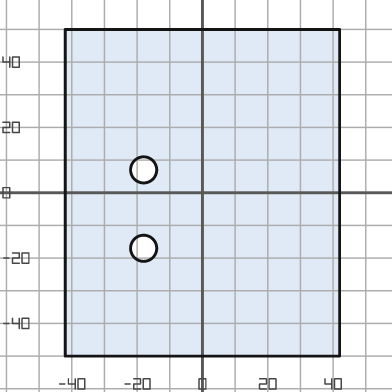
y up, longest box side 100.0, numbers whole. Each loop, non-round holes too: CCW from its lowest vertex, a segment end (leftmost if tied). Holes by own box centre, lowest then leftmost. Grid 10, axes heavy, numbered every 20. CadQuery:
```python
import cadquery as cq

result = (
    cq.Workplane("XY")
    .moveTo(-42.0, -50.0)
    .lineTo(42.0, -50.0)
    .lineTo(42.0, 50.0)
    .lineTo(-42.0, 50.0)
    .close()
    .moveTo(-18.0, -17.0)
    .circle(4.0)
    .moveTo(-18.0, 7.0)
    .circle(4.0)
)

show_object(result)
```